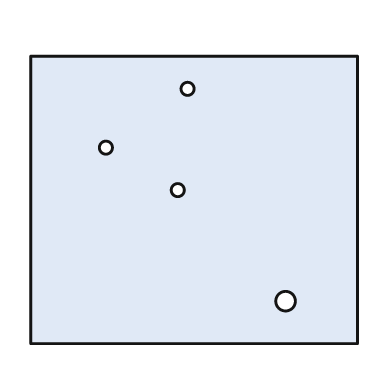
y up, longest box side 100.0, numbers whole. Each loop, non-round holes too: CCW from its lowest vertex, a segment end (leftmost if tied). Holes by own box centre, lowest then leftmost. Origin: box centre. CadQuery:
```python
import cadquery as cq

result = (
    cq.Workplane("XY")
    .moveTo(-50.0, -44.0)
    .lineTo(50.0, -44.0)
    .lineTo(50.0, 44.0)
    .lineTo(-50.0, 44.0)
    .close()
    .moveTo(28.0, -31.0)
    .circle(3.0)
    .moveTo(-5.0, 3.0)
    .circle(2.0)
    .moveTo(-27.0, 16.0)
    .circle(2.0)
    .moveTo(-2.0, 34.0)
    .circle(2.0)
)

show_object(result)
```